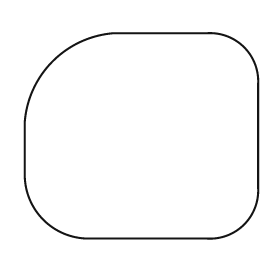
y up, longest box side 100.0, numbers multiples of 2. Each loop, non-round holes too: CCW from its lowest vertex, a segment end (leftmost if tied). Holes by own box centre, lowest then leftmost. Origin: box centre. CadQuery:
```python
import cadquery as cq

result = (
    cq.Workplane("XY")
    .moveTo(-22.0, -44.0)
    .lineTo(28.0, -44.0)
    .threePointArc((44.0, -38.0), (50.0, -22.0))
    .lineTo(50.0, 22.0)
    .threePointArc((44.0, 38.0), (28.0, 44.0))
    .lineTo(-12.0, 44.0)
    .threePointArc((-38.0, 32.0), (-50.0, 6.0))
    .lineTo(-50.0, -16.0)
    .threePointArc((-42.0, -36.0), (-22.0, -44.0))
    .close()
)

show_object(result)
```